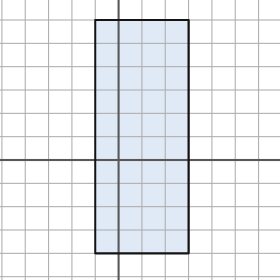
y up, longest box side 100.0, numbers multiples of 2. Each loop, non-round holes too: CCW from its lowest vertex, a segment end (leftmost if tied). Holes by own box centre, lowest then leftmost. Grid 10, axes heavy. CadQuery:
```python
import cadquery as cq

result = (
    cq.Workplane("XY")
    .moveTo(-10.0, -40.0)
    .lineTo(30.0, -40.0)
    .lineTo(30.0, 60.0)
    .lineTo(-10.0, 60.0)
    .close()
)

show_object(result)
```